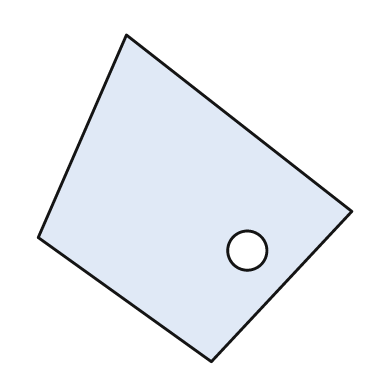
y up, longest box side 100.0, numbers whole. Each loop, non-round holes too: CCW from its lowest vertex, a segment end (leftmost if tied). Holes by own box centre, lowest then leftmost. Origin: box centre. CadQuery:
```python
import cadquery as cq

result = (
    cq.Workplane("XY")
    .moveTo(5.0, -50.0)
    .lineTo(48.0, -4.0)
    .lineTo(-21.0, 50.0)
    .lineTo(-48.0, -12.0)
    .close()
    .moveTo(16.0, -16.0)
    .circle(6.0)
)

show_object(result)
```